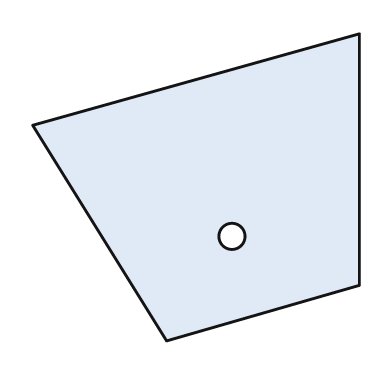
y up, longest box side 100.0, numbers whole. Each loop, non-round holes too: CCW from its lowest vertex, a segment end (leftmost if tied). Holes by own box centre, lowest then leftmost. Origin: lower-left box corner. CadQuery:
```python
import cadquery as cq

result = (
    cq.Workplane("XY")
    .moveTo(41.0, 0.0)
    .lineTo(100.0, 17.0)
    .lineTo(100.0, 94.0)
    .lineTo(0.0, 66.0)
    .close()
    .moveTo(61.0, 32.0)
    .circle(4.0)
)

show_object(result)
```